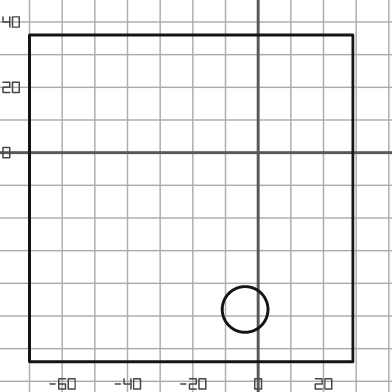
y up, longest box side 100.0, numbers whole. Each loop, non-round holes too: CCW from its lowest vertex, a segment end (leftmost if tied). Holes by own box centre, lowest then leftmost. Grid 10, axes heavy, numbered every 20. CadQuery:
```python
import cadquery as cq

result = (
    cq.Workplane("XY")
    .moveTo(-70.0, -64.0)
    .lineTo(29.0, -64.0)
    .lineTo(29.0, 36.0)
    .lineTo(-70.0, 36.0)
    .close()
    .moveTo(-4.0, -48.0)
    .circle(7.0)
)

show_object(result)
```